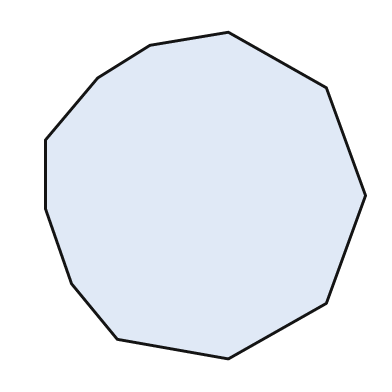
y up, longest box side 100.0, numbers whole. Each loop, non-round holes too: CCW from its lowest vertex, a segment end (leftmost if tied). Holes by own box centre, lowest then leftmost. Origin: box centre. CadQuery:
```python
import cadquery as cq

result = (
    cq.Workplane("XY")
    .moveTo(7.0, -50.0)
    .lineTo(37.0, -33.0)
    .lineTo(49.0, 0.0)
    .lineTo(37.0, 33.0)
    .lineTo(7.0, 50.0)
    .lineTo(-17.0, 46.0)
    .lineTo(-33.0, 36.0)
    .lineTo(-49.0, 17.0)
    .lineTo(-49.0, -4.0)
    .lineTo(-41.0, -27.0)
    .lineTo(-27.0, -44.0)
    .close()
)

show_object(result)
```